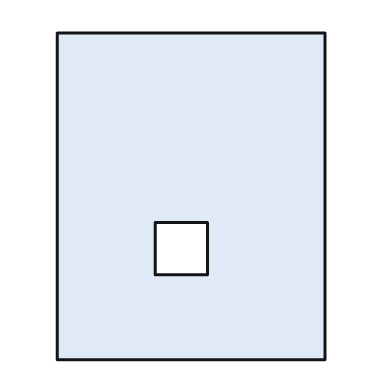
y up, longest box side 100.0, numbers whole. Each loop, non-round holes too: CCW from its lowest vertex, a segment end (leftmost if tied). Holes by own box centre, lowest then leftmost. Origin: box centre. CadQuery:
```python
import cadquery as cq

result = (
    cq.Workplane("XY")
    .moveTo(-41.0, -50.0)
    .lineTo(41.0, -50.0)
    .lineTo(41.0, 50.0)
    .lineTo(-41.0, 50.0)
    .close()
    .moveTo(-11.0, -24.0)
    .lineTo(5.0, -24.0)
    .lineTo(5.0, -8.0)
    .lineTo(-11.0, -8.0)
    .close()
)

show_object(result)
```